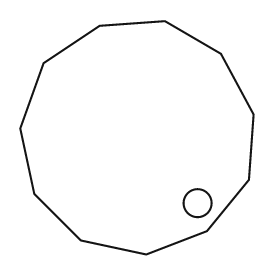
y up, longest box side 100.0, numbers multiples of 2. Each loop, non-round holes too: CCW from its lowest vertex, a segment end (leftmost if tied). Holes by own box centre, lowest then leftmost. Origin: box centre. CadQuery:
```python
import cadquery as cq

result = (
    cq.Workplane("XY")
    .moveTo(4.0, -50.0)
    .lineTo(30.0, -40.0)
    .lineTo(48.0, -18.0)
    .lineTo(50.0, 10.0)
    .lineTo(36.0, 36.0)
    .lineTo(12.0, 50.0)
    .lineTo(-16.0, 48.0)
    .lineTo(-40.0, 32.0)
    .lineTo(-50.0, 4.0)
    .lineTo(-44.0, -24.0)
    .lineTo(-24.0, -44.0)
    .close()
    .moveTo(26.0, -28.0)
    .circle(6.0)
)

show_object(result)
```